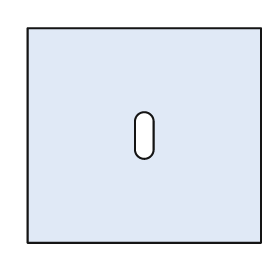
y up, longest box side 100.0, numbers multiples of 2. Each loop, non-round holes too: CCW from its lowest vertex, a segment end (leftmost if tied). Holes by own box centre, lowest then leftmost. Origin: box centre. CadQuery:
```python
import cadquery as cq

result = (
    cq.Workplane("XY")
    .moveTo(-50.0, -46.0)
    .lineTo(50.0, -46.0)
    .lineTo(50.0, 46.0)
    .lineTo(-50.0, 46.0)
    .close()
    .moveTo(-4.0, -6.0)
    .threePointArc((0.0, -10.0), (4.0, -6.0))
    .lineTo(4.0, 6.0)
    .threePointArc((0.0, 10.0), (-4.0, 6.0))
    .close()
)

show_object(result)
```